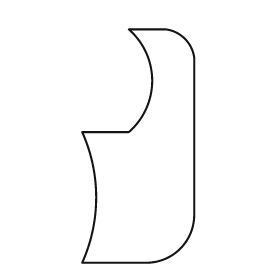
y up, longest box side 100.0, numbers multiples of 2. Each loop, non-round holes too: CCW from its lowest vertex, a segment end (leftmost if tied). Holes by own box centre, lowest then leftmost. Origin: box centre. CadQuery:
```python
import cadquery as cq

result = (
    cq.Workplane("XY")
    .moveTo(-24.0, -50.0)
    .lineTo(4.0, -50.0)
    .threePointArc((18.0, -44.0), (24.0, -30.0))
    .lineTo(24.0, 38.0)
    .threePointArc((20.0, 46.0), (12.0, 50.0))
    .lineTo(-4.0, 50.0)
    .threePointArc((6.0, 28.0), (-4.0, 6.0))
    .lineTo(-24.0, 6.0)
    .threePointArc((-18.0, -22.0), (-24.0, -50.0))
    .close()
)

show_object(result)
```